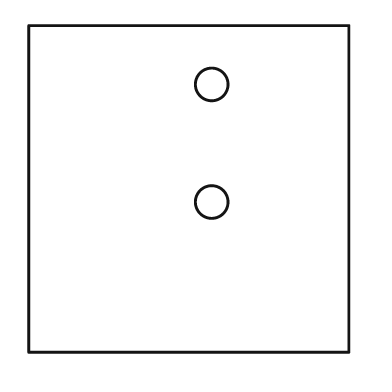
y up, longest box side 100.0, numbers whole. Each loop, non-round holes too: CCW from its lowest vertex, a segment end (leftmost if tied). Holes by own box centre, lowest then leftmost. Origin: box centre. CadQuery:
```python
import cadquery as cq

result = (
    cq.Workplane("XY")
    .moveTo(-49.0, -50.0)
    .lineTo(49.0, -50.0)
    .lineTo(49.0, 50.0)
    .lineTo(-49.0, 50.0)
    .close()
    .moveTo(7.0, -4.0)
    .circle(5.0)
    .moveTo(7.0, 32.0)
    .circle(5.0)
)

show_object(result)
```